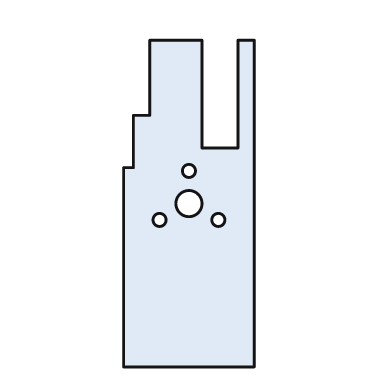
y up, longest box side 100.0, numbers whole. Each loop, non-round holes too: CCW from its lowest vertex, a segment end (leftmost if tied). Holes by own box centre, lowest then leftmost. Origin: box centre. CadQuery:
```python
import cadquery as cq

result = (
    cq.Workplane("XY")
    .moveTo(-20.0, -50.0)
    .lineTo(20.0, -50.0)
    .lineTo(20.0, 50.0)
    .lineTo(15.0, 50.0)
    .lineTo(15.0, 17.0)
    .lineTo(4.0, 17.0)
    .lineTo(4.0, 50.0)
    .lineTo(-12.0, 50.0)
    .lineTo(-12.0, 27.0)
    .lineTo(-17.0, 27.0)
    .lineTo(-17.0, 11.0)
    .lineTo(-20.0, 11.0)
    .close()
    .moveTo(-9.0, -5.0)
    .circle(2.0)
    .moveTo(9.0, -5.0)
    .circle(2.0)
    .moveTo(0.0, 0.0)
    .circle(4.0)
    .moveTo(0.0, 10.0)
    .circle(2.0)
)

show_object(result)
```